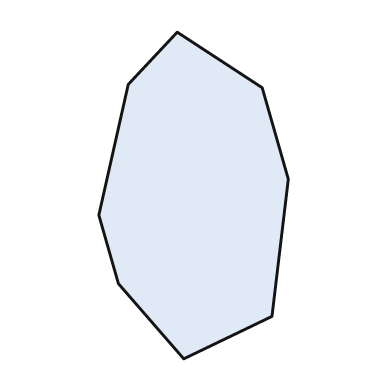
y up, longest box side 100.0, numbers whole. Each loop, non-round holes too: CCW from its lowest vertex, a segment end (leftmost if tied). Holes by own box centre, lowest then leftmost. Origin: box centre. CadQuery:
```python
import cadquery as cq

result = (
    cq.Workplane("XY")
    .moveTo(-3.0, -50.0)
    .lineTo(24.0, -37.0)
    .lineTo(29.0, 5.0)
    .lineTo(21.0, 33.0)
    .lineTo(-5.0, 50.0)
    .lineTo(-20.0, 34.0)
    .lineTo(-29.0, -6.0)
    .lineTo(-23.0, -27.0)
    .close()
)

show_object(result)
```